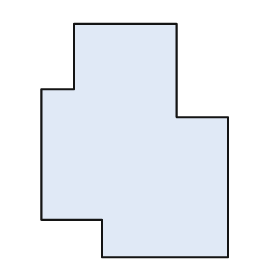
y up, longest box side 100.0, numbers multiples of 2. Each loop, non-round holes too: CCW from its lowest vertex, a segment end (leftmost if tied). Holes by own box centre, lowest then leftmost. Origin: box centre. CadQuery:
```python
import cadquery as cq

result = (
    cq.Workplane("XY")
    .moveTo(-14.0, -50.0)
    .lineTo(40.0, -50.0)
    .lineTo(40.0, 10.0)
    .lineTo(18.0, 10.0)
    .lineTo(18.0, 50.0)
    .lineTo(-26.0, 50.0)
    .lineTo(-26.0, 22.0)
    .lineTo(-40.0, 22.0)
    .lineTo(-40.0, -34.0)
    .lineTo(-14.0, -34.0)
    .close()
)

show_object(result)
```